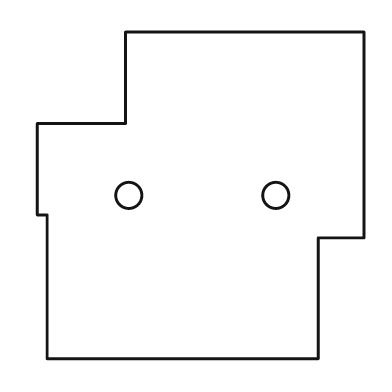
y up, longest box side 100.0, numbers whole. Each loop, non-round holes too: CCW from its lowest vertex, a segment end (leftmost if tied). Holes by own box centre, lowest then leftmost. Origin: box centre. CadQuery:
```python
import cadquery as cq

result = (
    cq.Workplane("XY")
    .moveTo(-47.0, -50.0)
    .lineTo(36.0, -50.0)
    .lineTo(36.0, -13.0)
    .lineTo(50.0, -13.0)
    .lineTo(50.0, 50.0)
    .lineTo(-23.0, 50.0)
    .lineTo(-23.0, 22.0)
    .lineTo(-50.0, 22.0)
    .lineTo(-50.0, -6.0)
    .lineTo(-47.0, -6.0)
    .close()
    .moveTo(-22.0, 0.0)
    .circle(4.0)
    .moveTo(23.0, 0.0)
    .circle(4.0)
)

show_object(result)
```